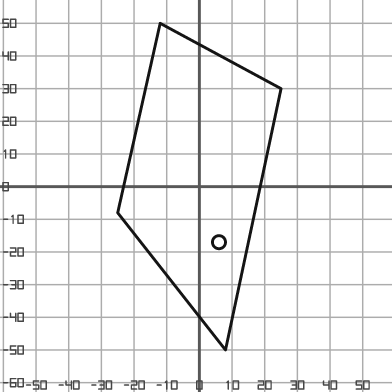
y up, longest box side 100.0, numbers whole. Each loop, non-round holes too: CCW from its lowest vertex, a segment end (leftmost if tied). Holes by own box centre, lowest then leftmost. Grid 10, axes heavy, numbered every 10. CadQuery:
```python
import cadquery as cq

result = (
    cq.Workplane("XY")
    .moveTo(8.0, -50.0)
    .lineTo(25.0, 30.0)
    .lineTo(-12.0, 50.0)
    .lineTo(-25.0, -8.0)
    .close()
    .moveTo(6.0, -17.0)
    .circle(2.0)
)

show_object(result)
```